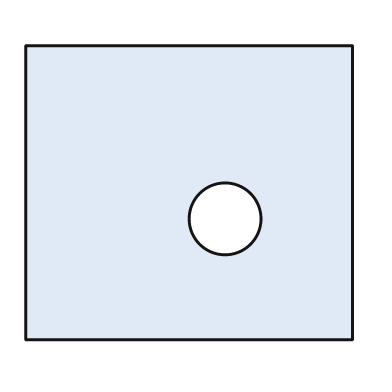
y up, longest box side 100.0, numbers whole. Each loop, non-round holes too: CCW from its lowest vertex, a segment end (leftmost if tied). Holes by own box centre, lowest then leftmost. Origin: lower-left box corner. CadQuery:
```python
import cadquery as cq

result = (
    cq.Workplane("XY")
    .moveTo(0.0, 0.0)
    .lineTo(100.0, 0.0)
    .lineTo(100.0, 90.0)
    .lineTo(0.0, 90.0)
    .close()
    .moveTo(61.0, 37.0)
    .circle(11.0)
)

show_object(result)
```